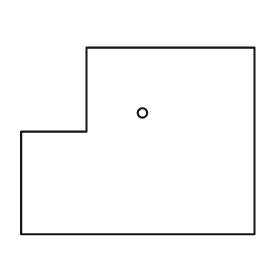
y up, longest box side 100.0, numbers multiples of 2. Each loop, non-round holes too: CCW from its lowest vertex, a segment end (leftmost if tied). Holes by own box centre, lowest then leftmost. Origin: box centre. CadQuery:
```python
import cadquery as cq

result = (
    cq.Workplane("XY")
    .moveTo(-50.0, -40.0)
    .lineTo(50.0, -40.0)
    .lineTo(50.0, 40.0)
    .lineTo(-22.0, 40.0)
    .lineTo(-22.0, 4.0)
    .lineTo(-50.0, 4.0)
    .close()
    .moveTo(2.0, 12.0)
    .circle(2.0)
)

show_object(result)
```